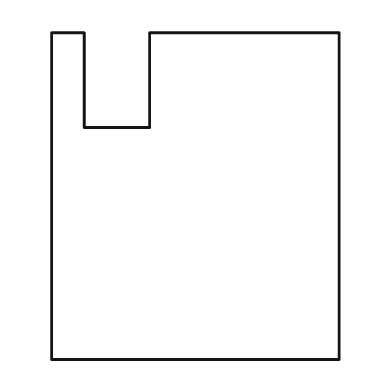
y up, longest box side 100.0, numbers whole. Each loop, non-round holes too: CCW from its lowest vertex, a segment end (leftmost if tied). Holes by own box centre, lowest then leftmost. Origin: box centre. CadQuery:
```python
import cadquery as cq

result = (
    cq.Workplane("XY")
    .moveTo(-44.0, -50.0)
    .lineTo(44.0, -50.0)
    .lineTo(44.0, 50.0)
    .lineTo(-14.0, 50.0)
    .lineTo(-14.0, 21.0)
    .lineTo(-34.0, 21.0)
    .lineTo(-34.0, 50.0)
    .lineTo(-44.0, 50.0)
    .close()
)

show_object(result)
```